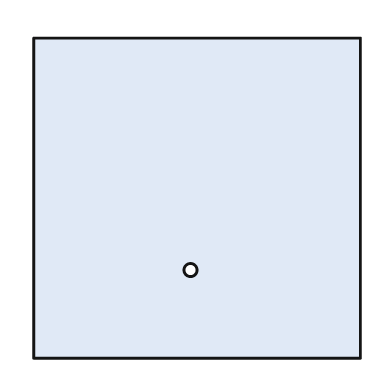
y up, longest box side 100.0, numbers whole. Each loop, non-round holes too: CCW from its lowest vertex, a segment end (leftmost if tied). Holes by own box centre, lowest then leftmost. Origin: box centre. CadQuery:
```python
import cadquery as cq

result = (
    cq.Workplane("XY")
    .moveTo(-50.0, -49.0)
    .lineTo(50.0, -49.0)
    .lineTo(50.0, 49.0)
    .lineTo(-50.0, 49.0)
    .close()
    .moveTo(-2.0, -22.0)
    .circle(2.0)
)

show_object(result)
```